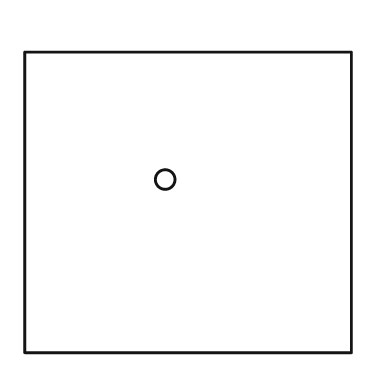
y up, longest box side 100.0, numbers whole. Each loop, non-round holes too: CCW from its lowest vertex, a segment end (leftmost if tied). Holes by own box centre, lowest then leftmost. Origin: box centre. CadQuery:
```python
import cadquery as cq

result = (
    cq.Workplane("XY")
    .moveTo(-50.0, -46.0)
    .lineTo(50.0, -46.0)
    .lineTo(50.0, 46.0)
    .lineTo(-50.0, 46.0)
    .close()
    .moveTo(-7.0, 7.0)
    .circle(3.0)
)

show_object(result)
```